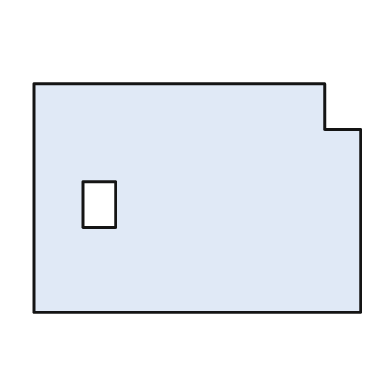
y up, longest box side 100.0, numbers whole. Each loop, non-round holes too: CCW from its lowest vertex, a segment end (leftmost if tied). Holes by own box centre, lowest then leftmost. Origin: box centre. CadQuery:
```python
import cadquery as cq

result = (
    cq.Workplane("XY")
    .moveTo(-50.0, -35.0)
    .lineTo(50.0, -35.0)
    .lineTo(50.0, 21.0)
    .lineTo(39.0, 21.0)
    .lineTo(39.0, 35.0)
    .lineTo(-50.0, 35.0)
    .close()
    .moveTo(-35.0, -9.0)
    .lineTo(-25.0, -9.0)
    .lineTo(-25.0, 5.0)
    .lineTo(-35.0, 5.0)
    .close()
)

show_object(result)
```